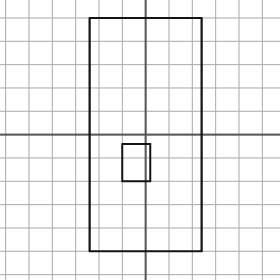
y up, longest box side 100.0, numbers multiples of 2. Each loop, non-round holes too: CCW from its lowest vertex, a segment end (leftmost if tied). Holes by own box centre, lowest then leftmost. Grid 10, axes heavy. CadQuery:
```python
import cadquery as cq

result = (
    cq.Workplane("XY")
    .moveTo(-24.0, -50.0)
    .lineTo(24.0, -50.0)
    .lineTo(24.0, 50.0)
    .lineTo(-24.0, 50.0)
    .close()
    .moveTo(-10.0, -20.0)
    .lineTo(2.0, -20.0)
    .lineTo(2.0, -4.0)
    .lineTo(-10.0, -4.0)
    .close()
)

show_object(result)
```